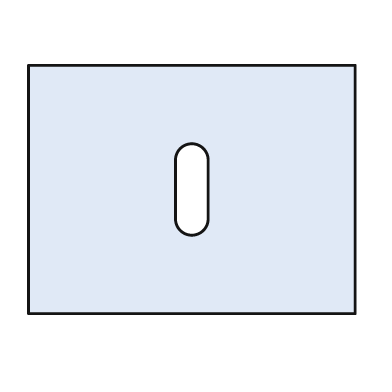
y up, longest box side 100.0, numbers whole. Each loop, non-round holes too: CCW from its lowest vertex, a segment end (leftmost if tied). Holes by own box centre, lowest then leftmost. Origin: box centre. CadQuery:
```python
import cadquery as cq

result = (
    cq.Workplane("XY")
    .moveTo(-50.0, -38.0)
    .lineTo(50.0, -38.0)
    .lineTo(50.0, 38.0)
    .lineTo(-50.0, 38.0)
    .close()
    .moveTo(-5.0, -9.0)
    .threePointArc((0.0, -14.0), (5.0, -9.0))
    .lineTo(5.0, 9.0)
    .threePointArc((0.0, 14.0), (-5.0, 9.0))
    .close()
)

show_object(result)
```